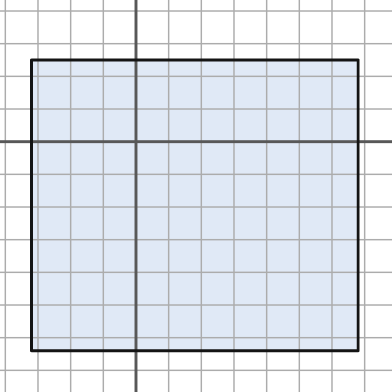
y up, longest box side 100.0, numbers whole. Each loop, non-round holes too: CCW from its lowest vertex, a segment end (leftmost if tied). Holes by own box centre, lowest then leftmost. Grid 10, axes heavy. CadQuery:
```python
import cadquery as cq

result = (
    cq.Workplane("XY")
    .moveTo(-32.0, -64.0)
    .lineTo(68.0, -64.0)
    .lineTo(68.0, 25.0)
    .lineTo(-32.0, 25.0)
    .close()
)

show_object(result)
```